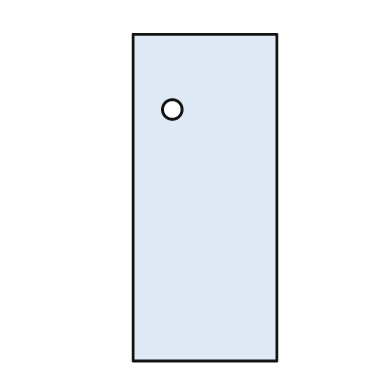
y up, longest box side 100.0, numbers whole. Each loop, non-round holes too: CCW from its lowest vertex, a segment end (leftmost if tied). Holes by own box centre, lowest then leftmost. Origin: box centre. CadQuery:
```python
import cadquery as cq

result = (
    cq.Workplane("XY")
    .moveTo(-22.0, -50.0)
    .lineTo(22.0, -50.0)
    .lineTo(22.0, 50.0)
    .lineTo(-22.0, 50.0)
    .close()
    .moveTo(-10.0, 27.0)
    .circle(3.0)
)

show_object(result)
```